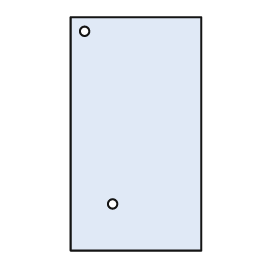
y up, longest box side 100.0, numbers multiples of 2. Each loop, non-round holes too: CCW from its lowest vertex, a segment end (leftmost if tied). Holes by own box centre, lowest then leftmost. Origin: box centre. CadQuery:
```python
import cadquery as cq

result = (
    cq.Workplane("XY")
    .moveTo(-28.0, -50.0)
    .lineTo(28.0, -50.0)
    .lineTo(28.0, 50.0)
    .lineTo(-28.0, 50.0)
    .close()
    .moveTo(-10.0, -30.0)
    .circle(2.0)
    .moveTo(-22.0, 44.0)
    .circle(2.0)
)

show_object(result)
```